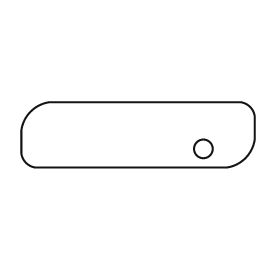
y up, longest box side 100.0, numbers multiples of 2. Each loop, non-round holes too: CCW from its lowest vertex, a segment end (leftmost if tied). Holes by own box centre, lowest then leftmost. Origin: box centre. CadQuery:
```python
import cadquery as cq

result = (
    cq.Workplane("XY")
    .moveTo(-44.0, -14.0)
    .lineTo(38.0, -14.0)
    .threePointArc((46.0, -10.0), (50.0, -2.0))
    .lineTo(50.0, 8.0)
    .threePointArc((48.0, 12.0), (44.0, 14.0))
    .lineTo(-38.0, 14.0)
    .threePointArc((-46.0, 10.0), (-50.0, 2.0))
    .lineTo(-50.0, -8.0)
    .threePointArc((-48.0, -12.0), (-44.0, -14.0))
    .close()
    .moveTo(28.0, -6.0)
    .circle(4.0)
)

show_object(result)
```